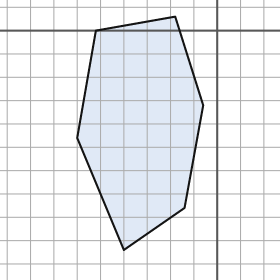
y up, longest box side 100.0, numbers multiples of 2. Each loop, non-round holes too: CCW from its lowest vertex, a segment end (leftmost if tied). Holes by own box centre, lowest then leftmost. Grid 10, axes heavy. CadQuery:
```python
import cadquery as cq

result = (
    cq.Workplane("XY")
    .moveTo(-40.0, -94.0)
    .lineTo(-14.0, -76.0)
    .lineTo(-6.0, -32.0)
    .lineTo(-18.0, 6.0)
    .lineTo(-52.0, 0.0)
    .lineTo(-60.0, -46.0)
    .close()
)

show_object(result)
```